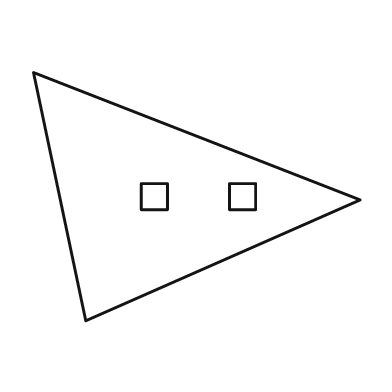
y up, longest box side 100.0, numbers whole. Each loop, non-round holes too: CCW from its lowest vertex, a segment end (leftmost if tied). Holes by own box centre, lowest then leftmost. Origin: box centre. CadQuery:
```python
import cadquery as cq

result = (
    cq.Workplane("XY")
    .moveTo(-34.0, -38.0)
    .lineTo(50.0, -1.0)
    .lineTo(-50.0, 38.0)
    .close()
    .moveTo(-17.0, -4.0)
    .lineTo(-9.0, -4.0)
    .lineTo(-9.0, 4.0)
    .lineTo(-17.0, 4.0)
    .close()
    .moveTo(10.0, -4.0)
    .lineTo(18.0, -4.0)
    .lineTo(18.0, 4.0)
    .lineTo(10.0, 4.0)
    .close()
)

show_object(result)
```